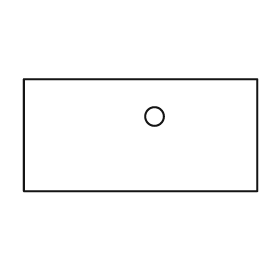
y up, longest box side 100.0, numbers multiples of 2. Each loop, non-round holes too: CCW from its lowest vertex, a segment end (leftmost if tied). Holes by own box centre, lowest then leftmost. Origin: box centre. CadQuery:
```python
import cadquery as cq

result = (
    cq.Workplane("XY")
    .moveTo(-50.0, -24.0)
    .lineTo(50.0, -24.0)
    .lineTo(50.0, 24.0)
    .lineTo(-50.0, 24.0)
    .close()
    .moveTo(6.0, 8.0)
    .circle(4.0)
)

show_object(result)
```